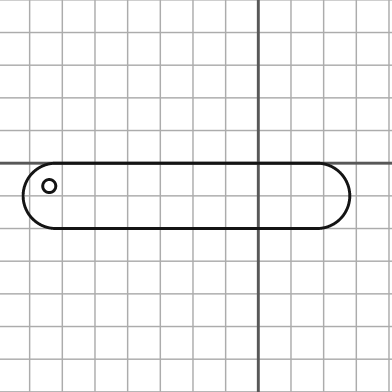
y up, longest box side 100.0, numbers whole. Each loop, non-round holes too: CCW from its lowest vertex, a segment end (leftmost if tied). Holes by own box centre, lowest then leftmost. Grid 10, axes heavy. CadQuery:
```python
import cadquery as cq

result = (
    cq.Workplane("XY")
    .moveTo(-62.0, -20.0)
    .lineTo(18.0, -20.0)
    .threePointArc((28.0, -10.0), (18.0, 0.0))
    .lineTo(-62.0, 0.0)
    .threePointArc((-72.0, -10.0), (-62.0, -20.0))
    .close()
    .moveTo(-64.0, -7.0)
    .circle(2.0)
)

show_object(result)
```